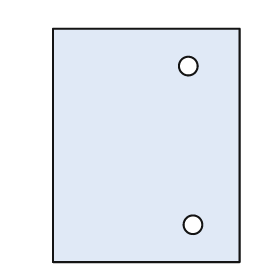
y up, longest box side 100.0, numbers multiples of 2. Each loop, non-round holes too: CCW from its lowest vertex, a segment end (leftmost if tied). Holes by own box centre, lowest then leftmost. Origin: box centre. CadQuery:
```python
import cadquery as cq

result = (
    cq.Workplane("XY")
    .moveTo(-40.0, -50.0)
    .lineTo(40.0, -50.0)
    .lineTo(40.0, 50.0)
    .lineTo(-40.0, 50.0)
    .close()
    .moveTo(20.0, -34.0)
    .circle(4.0)
    .moveTo(18.0, 34.0)
    .circle(4.0)
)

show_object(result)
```